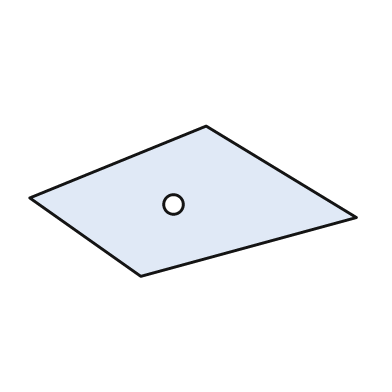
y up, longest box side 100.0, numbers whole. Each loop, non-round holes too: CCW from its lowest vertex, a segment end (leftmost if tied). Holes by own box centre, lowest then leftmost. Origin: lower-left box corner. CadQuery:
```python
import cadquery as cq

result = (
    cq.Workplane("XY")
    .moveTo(34.0, 0.0)
    .lineTo(100.0, 18.0)
    .lineTo(54.0, 46.0)
    .lineTo(0.0, 24.0)
    .close()
    .moveTo(44.0, 22.0)
    .circle(3.0)
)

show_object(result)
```